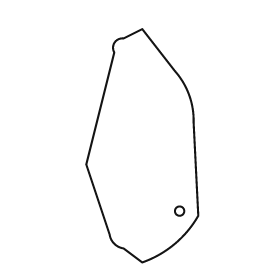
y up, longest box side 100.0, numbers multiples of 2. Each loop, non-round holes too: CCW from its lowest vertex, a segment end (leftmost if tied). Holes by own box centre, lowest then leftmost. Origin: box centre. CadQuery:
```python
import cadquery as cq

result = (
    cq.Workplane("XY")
    .moveTo(0.0, -50.0)
    .threePointArc((14.0, -42.0), (24.0, -30.0))
    .lineTo(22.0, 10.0)
    .threePointArc((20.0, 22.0), (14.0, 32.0))
    .lineTo(0.0, 50.0)
    .lineTo(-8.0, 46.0)
    .threePointArc((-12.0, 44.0), (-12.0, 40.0))
    .lineTo(-24.0, -8.0)
    .lineTo(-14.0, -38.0)
    .threePointArc((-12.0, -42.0), (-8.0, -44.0))
    .close()
    .moveTo(16.0, -28.0)
    .circle(2.0)
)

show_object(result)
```